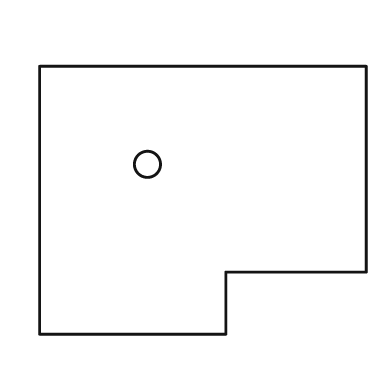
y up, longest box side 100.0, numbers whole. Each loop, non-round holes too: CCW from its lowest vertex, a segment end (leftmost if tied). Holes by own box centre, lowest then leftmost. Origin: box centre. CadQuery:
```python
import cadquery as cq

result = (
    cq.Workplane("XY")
    .moveTo(-50.0, -41.0)
    .lineTo(7.0, -41.0)
    .lineTo(7.0, -22.0)
    .lineTo(50.0, -22.0)
    .lineTo(50.0, 41.0)
    .lineTo(-50.0, 41.0)
    .close()
    .moveTo(-17.0, 11.0)
    .circle(4.0)
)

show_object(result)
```